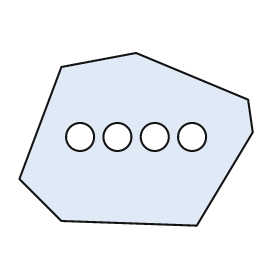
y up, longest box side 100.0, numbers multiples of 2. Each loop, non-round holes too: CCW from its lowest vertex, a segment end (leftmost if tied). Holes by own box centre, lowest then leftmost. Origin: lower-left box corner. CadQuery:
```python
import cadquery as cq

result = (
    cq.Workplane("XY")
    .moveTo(76.0, 0.0)
    .lineTo(100.0, 40.0)
    .lineTo(98.0, 54.0)
    .lineTo(50.0, 74.0)
    .lineTo(18.0, 68.0)
    .lineTo(0.0, 20.0)
    .lineTo(18.0, 2.0)
    .close()
    .moveTo(26.0, 38.0)
    .circle(6.0)
    .moveTo(42.0, 38.0)
    .circle(6.0)
    .moveTo(58.0, 38.0)
    .circle(6.0)
    .moveTo(74.0, 38.0)
    .circle(6.0)
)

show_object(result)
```